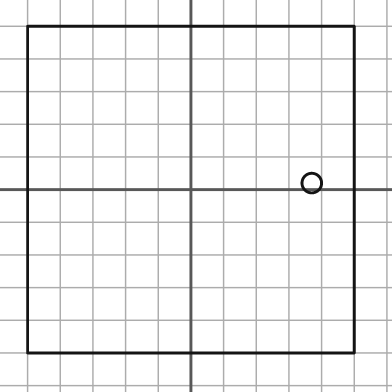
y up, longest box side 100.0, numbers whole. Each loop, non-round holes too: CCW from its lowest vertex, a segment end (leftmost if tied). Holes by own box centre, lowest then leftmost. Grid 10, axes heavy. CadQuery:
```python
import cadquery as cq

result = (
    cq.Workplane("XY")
    .moveTo(-50.0, -50.0)
    .lineTo(50.0, -50.0)
    .lineTo(50.0, 50.0)
    .lineTo(-50.0, 50.0)
    .close()
    .moveTo(37.0, 2.0)
    .circle(3.0)
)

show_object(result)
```